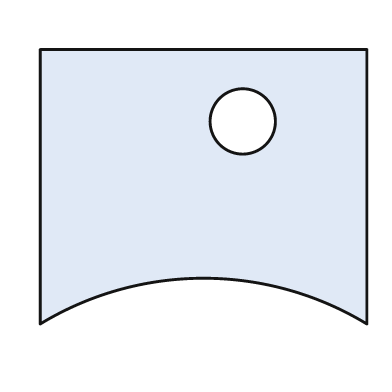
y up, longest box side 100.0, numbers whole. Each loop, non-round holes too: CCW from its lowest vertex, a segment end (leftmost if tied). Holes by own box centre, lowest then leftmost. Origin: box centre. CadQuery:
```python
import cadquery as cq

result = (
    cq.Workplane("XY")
    .moveTo(-50.0, -42.0)
    .threePointArc((0.0, -28.0), (50.0, -42.0))
    .lineTo(50.0, 42.0)
    .lineTo(-50.0, 42.0)
    .close()
    .moveTo(12.0, 20.0)
    .circle(10.0)
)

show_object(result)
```